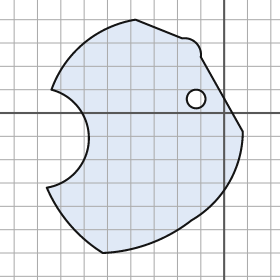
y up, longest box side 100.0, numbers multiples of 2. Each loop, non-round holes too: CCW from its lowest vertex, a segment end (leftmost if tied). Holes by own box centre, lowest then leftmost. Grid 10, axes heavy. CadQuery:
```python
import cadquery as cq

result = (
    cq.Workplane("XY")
    .moveTo(-52.0, -60.0)
    .threePointArc((-32.0, -56.0), (-14.0, -46.0))
    .threePointArc((2.0, -30.0), (8.0, -8.0))
    .lineTo(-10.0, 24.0)
    .threePointArc((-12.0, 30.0), (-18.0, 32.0))
    .lineTo(-38.0, 40.0)
    .threePointArc((-60.0, 30.0), (-74.0, 10.0))
    .threePointArc((-58.0, -12.0), (-76.0, -32.0))
    .threePointArc((-66.0, -48.0), (-52.0, -60.0))
    .close()
    .moveTo(-12.0, 6.0)
    .circle(4.0)
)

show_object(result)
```